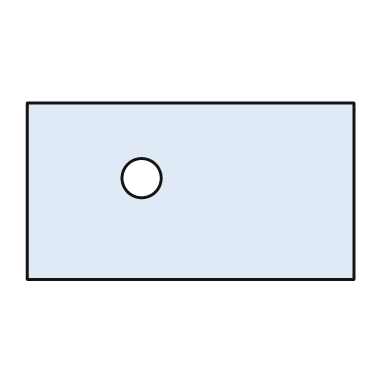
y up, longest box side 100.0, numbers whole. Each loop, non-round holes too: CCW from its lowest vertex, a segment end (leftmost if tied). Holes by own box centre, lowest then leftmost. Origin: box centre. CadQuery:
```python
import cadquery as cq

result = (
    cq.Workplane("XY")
    .moveTo(-50.0, -27.0)
    .lineTo(50.0, -27.0)
    .lineTo(50.0, 27.0)
    .lineTo(-50.0, 27.0)
    .close()
    .moveTo(-15.0, 4.0)
    .circle(6.0)
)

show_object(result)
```